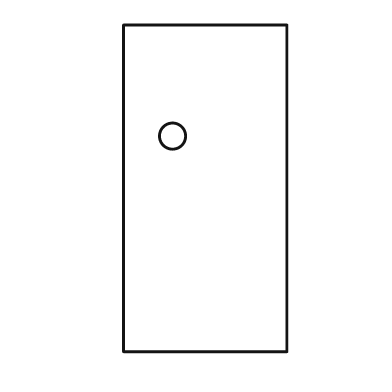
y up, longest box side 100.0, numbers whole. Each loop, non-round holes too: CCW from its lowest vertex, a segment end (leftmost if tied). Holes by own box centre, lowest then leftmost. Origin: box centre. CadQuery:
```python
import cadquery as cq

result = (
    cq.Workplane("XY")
    .moveTo(-25.0, -50.0)
    .lineTo(25.0, -50.0)
    .lineTo(25.0, 50.0)
    .lineTo(-25.0, 50.0)
    .close()
    .moveTo(-10.0, 16.0)
    .circle(4.0)
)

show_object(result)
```